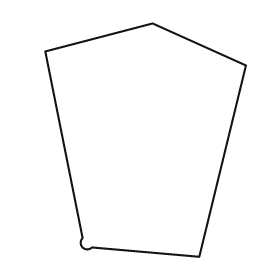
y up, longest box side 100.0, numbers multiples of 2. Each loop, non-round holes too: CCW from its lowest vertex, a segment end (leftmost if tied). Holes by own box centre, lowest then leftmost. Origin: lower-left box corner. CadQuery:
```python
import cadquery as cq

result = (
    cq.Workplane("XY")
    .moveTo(66.0, 0.0)
    .lineTo(86.0, 82.0)
    .lineTo(46.0, 100.0)
    .lineTo(0.0, 88.0)
    .lineTo(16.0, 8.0)
    .threePointArc((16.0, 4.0), (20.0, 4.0))
    .close()
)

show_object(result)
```